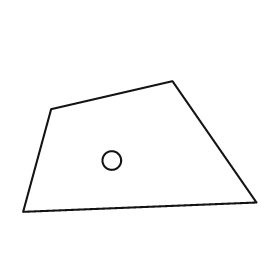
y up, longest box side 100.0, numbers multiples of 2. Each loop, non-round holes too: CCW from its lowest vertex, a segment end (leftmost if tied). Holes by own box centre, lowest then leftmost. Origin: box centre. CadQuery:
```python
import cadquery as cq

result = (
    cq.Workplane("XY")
    .moveTo(-50.0, -28.0)
    .lineTo(50.0, -24.0)
    .lineTo(14.0, 28.0)
    .lineTo(-38.0, 16.0)
    .close()
    .moveTo(-12.0, -6.0)
    .circle(4.0)
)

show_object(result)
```